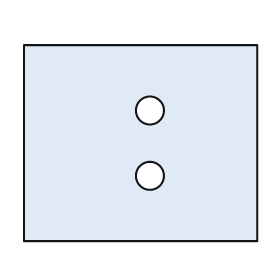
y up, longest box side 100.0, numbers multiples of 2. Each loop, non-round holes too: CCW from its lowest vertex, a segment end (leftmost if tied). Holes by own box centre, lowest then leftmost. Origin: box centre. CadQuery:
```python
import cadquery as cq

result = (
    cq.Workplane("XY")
    .moveTo(-50.0, -42.0)
    .lineTo(50.0, -42.0)
    .lineTo(50.0, 42.0)
    .lineTo(-50.0, 42.0)
    .close()
    .moveTo(4.0, -14.0)
    .circle(6.0)
    .moveTo(4.0, 14.0)
    .circle(6.0)
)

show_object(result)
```